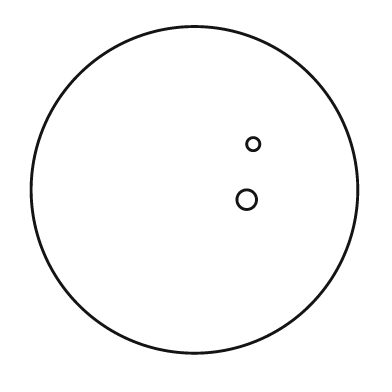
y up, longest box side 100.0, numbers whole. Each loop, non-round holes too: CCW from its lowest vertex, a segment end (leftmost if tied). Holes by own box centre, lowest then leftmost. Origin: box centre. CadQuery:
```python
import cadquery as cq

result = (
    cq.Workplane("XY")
    .moveTo(0.0, 0.0)
    .circle(50.0)
    .moveTo(16.0, -3.0)
    .circle(3.0)
    .moveTo(18.0, 14.0)
    .circle(2.0)
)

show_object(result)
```